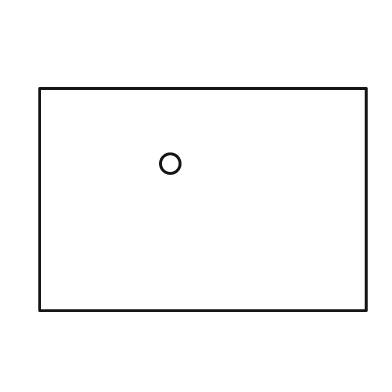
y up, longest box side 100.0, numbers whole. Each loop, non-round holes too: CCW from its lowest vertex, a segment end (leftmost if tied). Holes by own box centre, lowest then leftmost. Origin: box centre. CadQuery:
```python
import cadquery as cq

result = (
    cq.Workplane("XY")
    .moveTo(-50.0, -34.0)
    .lineTo(50.0, -34.0)
    .lineTo(50.0, 34.0)
    .lineTo(-50.0, 34.0)
    .close()
    .moveTo(-10.0, 11.0)
    .circle(3.0)
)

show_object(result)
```